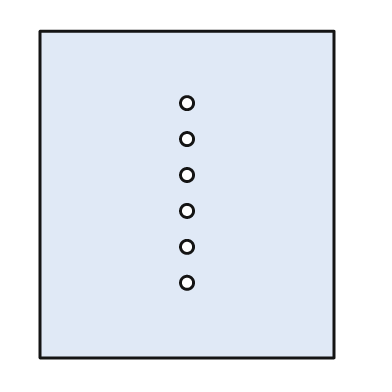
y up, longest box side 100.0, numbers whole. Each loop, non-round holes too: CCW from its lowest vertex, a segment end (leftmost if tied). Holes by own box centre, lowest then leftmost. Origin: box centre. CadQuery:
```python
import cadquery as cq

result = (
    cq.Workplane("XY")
    .moveTo(-45.0, -50.0)
    .lineTo(45.0, -50.0)
    .lineTo(45.0, 50.0)
    .lineTo(-45.0, 50.0)
    .close()
    .moveTo(0.0, -27.0)
    .circle(2.0)
    .moveTo(0.0, -16.0)
    .circle(2.0)
    .moveTo(0.0, -5.0)
    .circle(2.0)
    .moveTo(0.0, 6.0)
    .circle(2.0)
    .moveTo(0.0, 17.0)
    .circle(2.0)
    .moveTo(0.0, 28.0)
    .circle(2.0)
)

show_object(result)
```